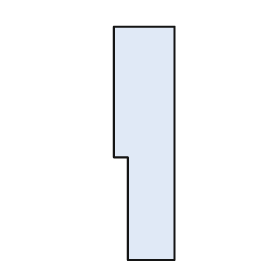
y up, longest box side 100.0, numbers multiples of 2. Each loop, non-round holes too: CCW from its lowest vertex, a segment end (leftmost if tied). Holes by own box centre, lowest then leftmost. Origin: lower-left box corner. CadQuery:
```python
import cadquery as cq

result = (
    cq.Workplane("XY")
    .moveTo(6.0, 0.0)
    .lineTo(26.0, 0.0)
    .lineTo(26.0, 100.0)
    .lineTo(0.0, 100.0)
    .lineTo(0.0, 44.0)
    .lineTo(6.0, 44.0)
    .close()
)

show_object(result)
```